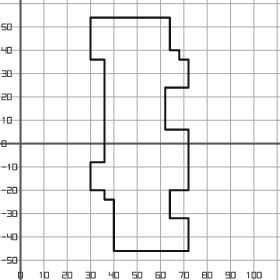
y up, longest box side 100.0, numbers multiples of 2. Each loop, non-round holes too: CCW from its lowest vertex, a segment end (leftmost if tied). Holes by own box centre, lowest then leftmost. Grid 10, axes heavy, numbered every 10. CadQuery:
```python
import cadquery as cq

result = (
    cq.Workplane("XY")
    .moveTo(40.0, -46.0)
    .lineTo(72.0, -46.0)
    .lineTo(72.0, -32.0)
    .lineTo(64.0, -32.0)
    .lineTo(64.0, -20.0)
    .lineTo(72.0, -20.0)
    .lineTo(72.0, 6.0)
    .lineTo(62.0, 6.0)
    .lineTo(62.0, 24.0)
    .lineTo(72.0, 24.0)
    .lineTo(72.0, 36.0)
    .lineTo(68.0, 36.0)
    .lineTo(68.0, 40.0)
    .lineTo(64.0, 40.0)
    .lineTo(64.0, 54.0)
    .lineTo(30.0, 54.0)
    .lineTo(30.0, 36.0)
    .lineTo(36.0, 36.0)
    .lineTo(36.0, -8.0)
    .lineTo(30.0, -8.0)
    .lineTo(30.0, -20.0)
    .lineTo(36.0, -20.0)
    .lineTo(36.0, -24.0)
    .lineTo(40.0, -24.0)
    .close()
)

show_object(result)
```